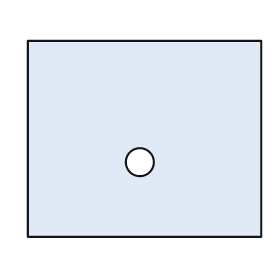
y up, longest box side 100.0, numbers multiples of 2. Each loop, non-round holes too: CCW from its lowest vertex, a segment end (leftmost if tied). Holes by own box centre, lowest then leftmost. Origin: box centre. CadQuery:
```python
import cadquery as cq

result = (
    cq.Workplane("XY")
    .moveTo(-50.0, -42.0)
    .lineTo(50.0, -42.0)
    .lineTo(50.0, 42.0)
    .lineTo(-50.0, 42.0)
    .close()
    .moveTo(-2.0, -10.0)
    .circle(6.0)
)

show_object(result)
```